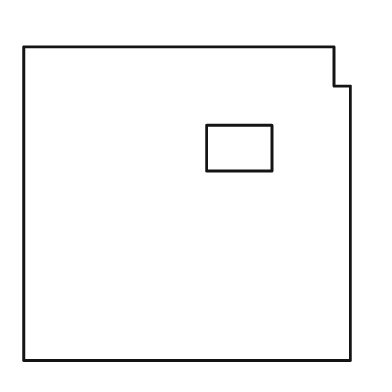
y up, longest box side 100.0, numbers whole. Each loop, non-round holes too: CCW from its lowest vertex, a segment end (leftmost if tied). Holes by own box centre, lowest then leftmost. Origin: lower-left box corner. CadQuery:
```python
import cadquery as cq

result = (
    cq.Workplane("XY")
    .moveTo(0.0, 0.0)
    .lineTo(100.0, 0.0)
    .lineTo(100.0, 84.0)
    .lineTo(95.0, 84.0)
    .lineTo(95.0, 96.0)
    .lineTo(0.0, 96.0)
    .close()
    .moveTo(56.0, 58.0)
    .lineTo(76.0, 58.0)
    .lineTo(76.0, 72.0)
    .lineTo(56.0, 72.0)
    .close()
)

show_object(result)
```